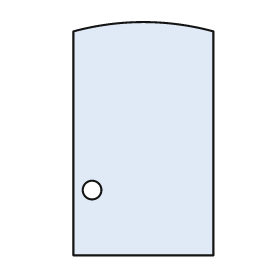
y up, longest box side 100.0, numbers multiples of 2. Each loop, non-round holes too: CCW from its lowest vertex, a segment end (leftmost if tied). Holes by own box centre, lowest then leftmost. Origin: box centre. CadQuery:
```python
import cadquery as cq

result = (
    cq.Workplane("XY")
    .moveTo(-30.0, -50.0)
    .lineTo(30.0, -50.0)
    .lineTo(30.0, 46.0)
    .threePointArc((0.0, 50.0), (-30.0, 46.0))
    .close()
    .moveTo(-22.0, -22.0)
    .circle(4.0)
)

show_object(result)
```